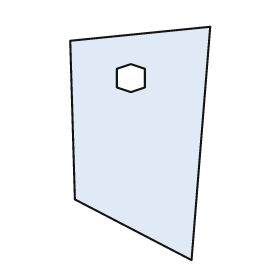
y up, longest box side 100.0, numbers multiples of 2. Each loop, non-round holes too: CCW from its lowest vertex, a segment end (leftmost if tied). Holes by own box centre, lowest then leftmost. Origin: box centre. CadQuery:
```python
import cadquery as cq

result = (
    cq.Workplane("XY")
    .moveTo(22.0, -50.0)
    .lineTo(30.0, 50.0)
    .lineTo(-30.0, 44.0)
    .lineTo(-28.0, -24.0)
    .close()
    .moveTo(-4.0, 22.0)
    .lineTo(2.0, 24.0)
    .lineTo(2.0, 32.0)
    .lineTo(-4.0, 34.0)
    .lineTo(-10.0, 32.0)
    .lineTo(-10.0, 24.0)
    .close()
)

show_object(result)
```